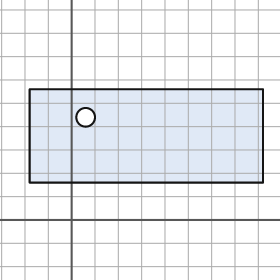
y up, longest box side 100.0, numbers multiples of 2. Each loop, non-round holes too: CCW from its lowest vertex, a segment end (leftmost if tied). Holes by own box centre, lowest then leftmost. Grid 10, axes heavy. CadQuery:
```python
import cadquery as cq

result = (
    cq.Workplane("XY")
    .moveTo(-18.0, 16.0)
    .lineTo(82.0, 16.0)
    .lineTo(82.0, 56.0)
    .lineTo(-18.0, 56.0)
    .close()
    .moveTo(6.0, 44.0)
    .circle(4.0)
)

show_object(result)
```